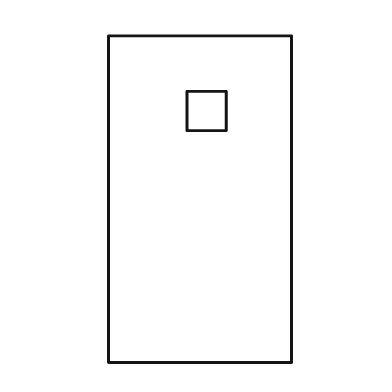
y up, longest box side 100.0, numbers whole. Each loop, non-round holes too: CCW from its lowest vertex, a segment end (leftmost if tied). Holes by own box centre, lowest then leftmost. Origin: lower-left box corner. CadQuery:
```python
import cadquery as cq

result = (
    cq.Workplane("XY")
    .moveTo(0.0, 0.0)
    .lineTo(56.0, 0.0)
    .lineTo(56.0, 100.0)
    .lineTo(0.0, 100.0)
    .close()
    .moveTo(24.0, 71.0)
    .lineTo(36.0, 71.0)
    .lineTo(36.0, 83.0)
    .lineTo(24.0, 83.0)
    .close()
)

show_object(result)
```